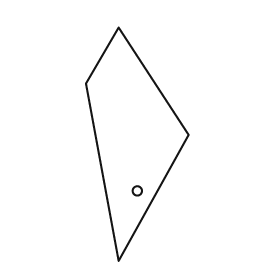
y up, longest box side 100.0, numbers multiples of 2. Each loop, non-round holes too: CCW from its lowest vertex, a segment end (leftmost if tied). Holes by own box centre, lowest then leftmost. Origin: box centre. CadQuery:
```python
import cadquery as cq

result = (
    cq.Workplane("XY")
    .moveTo(-8.0, -50.0)
    .lineTo(22.0, 4.0)
    .lineTo(-8.0, 50.0)
    .lineTo(-22.0, 26.0)
    .close()
    .moveTo(0.0, -20.0)
    .circle(2.0)
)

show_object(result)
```